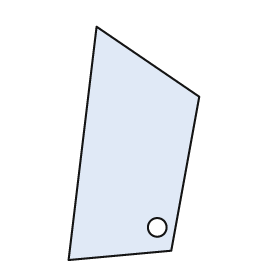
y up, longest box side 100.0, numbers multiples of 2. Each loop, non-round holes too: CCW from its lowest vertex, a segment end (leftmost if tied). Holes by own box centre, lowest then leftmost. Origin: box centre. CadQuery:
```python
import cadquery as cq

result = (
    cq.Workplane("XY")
    .moveTo(-28.0, -50.0)
    .lineTo(16.0, -46.0)
    .lineTo(28.0, 20.0)
    .lineTo(-16.0, 50.0)
    .close()
    .moveTo(10.0, -36.0)
    .circle(4.0)
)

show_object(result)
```